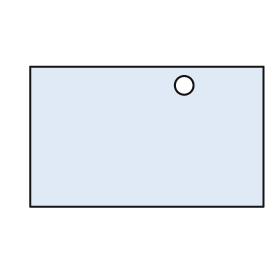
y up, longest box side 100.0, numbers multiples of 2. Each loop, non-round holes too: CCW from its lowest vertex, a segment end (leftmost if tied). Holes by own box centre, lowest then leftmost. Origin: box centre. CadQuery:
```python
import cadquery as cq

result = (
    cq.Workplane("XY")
    .moveTo(-50.0, -30.0)
    .lineTo(50.0, -30.0)
    .lineTo(50.0, 30.0)
    .lineTo(-50.0, 30.0)
    .close()
    .moveTo(16.0, 22.0)
    .circle(4.0)
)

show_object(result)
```